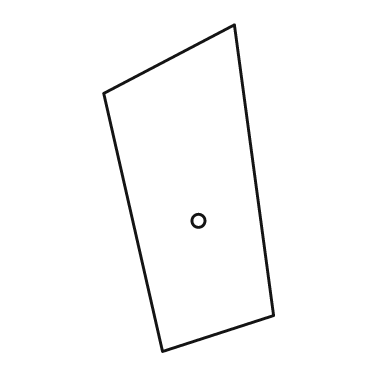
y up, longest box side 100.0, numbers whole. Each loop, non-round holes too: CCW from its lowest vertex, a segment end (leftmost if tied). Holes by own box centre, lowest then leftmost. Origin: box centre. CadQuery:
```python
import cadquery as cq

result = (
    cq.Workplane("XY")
    .moveTo(-8.0, -50.0)
    .lineTo(26.0, -39.0)
    .lineTo(14.0, 50.0)
    .lineTo(-26.0, 29.0)
    .close()
    .moveTo(3.0, -10.0)
    .circle(2.0)
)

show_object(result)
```